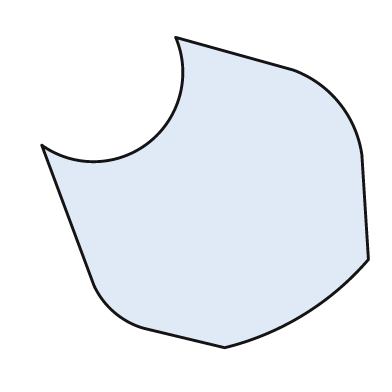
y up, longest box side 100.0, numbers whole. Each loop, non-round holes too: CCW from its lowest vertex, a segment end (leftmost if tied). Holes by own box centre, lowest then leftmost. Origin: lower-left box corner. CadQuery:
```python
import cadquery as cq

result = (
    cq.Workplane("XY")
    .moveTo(56.0, 0.0)
    .threePointArc((80.0, 10.0), (100.0, 27.0))
    .lineTo(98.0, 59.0)
    .threePointArc((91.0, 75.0), (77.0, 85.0))
    .lineTo(41.0, 95.0)
    .threePointArc((33.0, 63.0), (0.0, 62.0))
    .lineTo(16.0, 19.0)
    .threePointArc((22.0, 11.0), (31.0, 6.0))
    .close()
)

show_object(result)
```